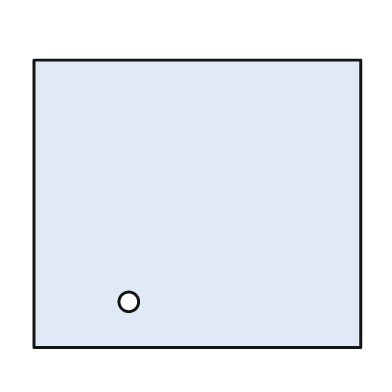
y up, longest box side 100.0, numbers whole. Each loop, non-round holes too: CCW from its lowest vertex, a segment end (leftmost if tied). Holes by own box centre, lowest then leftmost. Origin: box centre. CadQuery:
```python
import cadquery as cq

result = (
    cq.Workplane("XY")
    .moveTo(-50.0, -44.0)
    .lineTo(50.0, -44.0)
    .lineTo(50.0, 44.0)
    .lineTo(-50.0, 44.0)
    .close()
    .moveTo(-21.0, -30.0)
    .circle(3.0)
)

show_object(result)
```